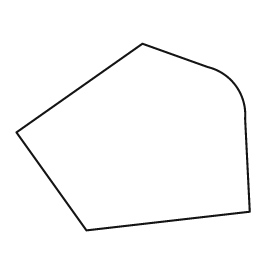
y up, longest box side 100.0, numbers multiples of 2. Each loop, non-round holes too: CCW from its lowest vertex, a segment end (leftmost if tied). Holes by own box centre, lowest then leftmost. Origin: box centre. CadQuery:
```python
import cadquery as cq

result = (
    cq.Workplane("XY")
    .moveTo(-20.0, -40.0)
    .lineTo(50.0, -32.0)
    .lineTo(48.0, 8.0)
    .threePointArc((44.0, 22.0), (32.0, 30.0))
    .lineTo(4.0, 40.0)
    .lineTo(-50.0, 2.0)
    .close()
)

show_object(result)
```